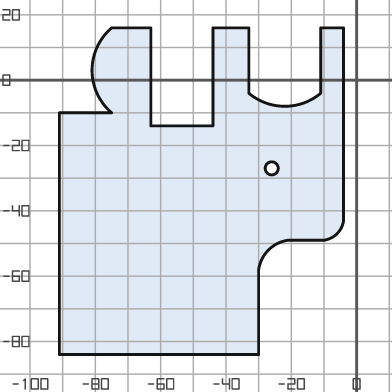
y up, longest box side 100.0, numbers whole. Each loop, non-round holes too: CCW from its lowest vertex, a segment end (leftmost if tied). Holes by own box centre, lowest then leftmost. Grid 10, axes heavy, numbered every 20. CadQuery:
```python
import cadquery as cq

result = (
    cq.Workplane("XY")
    .moveTo(-91.0, -84.0)
    .lineTo(-30.0, -84.0)
    .lineTo(-30.0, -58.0)
    .threePointArc((-27.0, -52.0), (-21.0, -49.0))
    .lineTo(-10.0, -49.0)
    .threePointArc((-6.0, -47.0), (-4.0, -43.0))
    .lineTo(-4.0, 16.0)
    .lineTo(-11.0, 16.0)
    .lineTo(-11.0, -4.0)
    .threePointArc((-22.0, -8.0), (-33.0, -4.0))
    .lineTo(-33.0, 16.0)
    .lineTo(-44.0, 16.0)
    .lineTo(-44.0, -14.0)
    .lineTo(-63.0, -14.0)
    .lineTo(-63.0, 16.0)
    .lineTo(-75.0, 16.0)
    .threePointArc((-81.0, 3.0), (-75.0, -10.0))
    .lineTo(-91.0, -10.0)
    .close()
    .moveTo(-26.0, -27.0)
    .circle(2.0)
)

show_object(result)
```